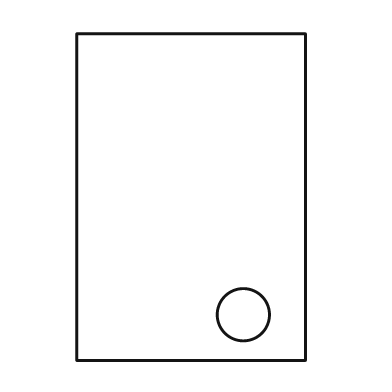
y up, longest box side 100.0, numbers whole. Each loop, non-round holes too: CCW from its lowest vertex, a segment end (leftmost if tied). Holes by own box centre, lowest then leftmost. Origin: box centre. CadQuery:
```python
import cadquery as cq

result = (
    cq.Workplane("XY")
    .moveTo(-35.0, -50.0)
    .lineTo(35.0, -50.0)
    .lineTo(35.0, 50.0)
    .lineTo(-35.0, 50.0)
    .close()
    .moveTo(16.0, -36.0)
    .circle(8.0)
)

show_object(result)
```